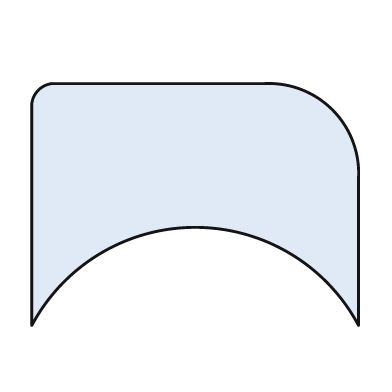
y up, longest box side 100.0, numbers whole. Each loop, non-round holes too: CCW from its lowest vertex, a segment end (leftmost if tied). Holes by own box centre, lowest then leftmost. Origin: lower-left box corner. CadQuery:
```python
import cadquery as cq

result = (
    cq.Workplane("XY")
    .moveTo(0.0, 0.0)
    .threePointArc((50.0, 30.0), (100.0, 0.0))
    .lineTo(100.0, 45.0)
    .threePointArc((92.0, 66.0), (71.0, 74.0))
    .lineTo(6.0, 74.0)
    .threePointArc((2.0, 72.0), (0.0, 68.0))
    .close()
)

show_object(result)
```